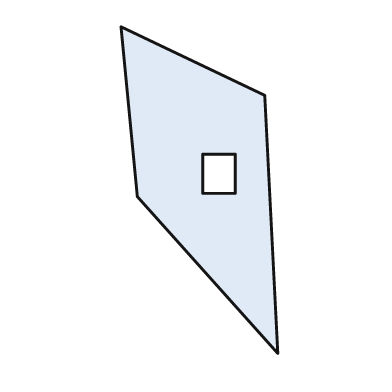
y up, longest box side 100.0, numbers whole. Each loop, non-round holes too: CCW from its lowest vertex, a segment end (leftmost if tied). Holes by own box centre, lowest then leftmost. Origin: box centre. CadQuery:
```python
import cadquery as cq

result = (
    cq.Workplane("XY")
    .moveTo(24.0, -50.0)
    .lineTo(20.0, 29.0)
    .lineTo(-24.0, 50.0)
    .lineTo(-19.0, -2.0)
    .close()
    .moveTo(1.0, -1.0)
    .lineTo(11.0, -1.0)
    .lineTo(11.0, 11.0)
    .lineTo(1.0, 11.0)
    .close()
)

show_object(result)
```